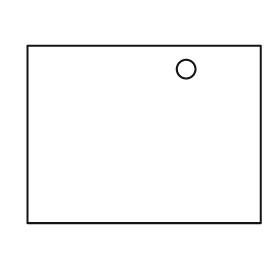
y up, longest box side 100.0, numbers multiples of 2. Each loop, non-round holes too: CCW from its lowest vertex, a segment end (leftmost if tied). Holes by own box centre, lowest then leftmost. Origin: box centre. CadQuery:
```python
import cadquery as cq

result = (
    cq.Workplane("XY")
    .moveTo(-50.0, -38.0)
    .lineTo(50.0, -38.0)
    .lineTo(50.0, 38.0)
    .lineTo(-50.0, 38.0)
    .close()
    .moveTo(18.0, 28.0)
    .circle(4.0)
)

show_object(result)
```